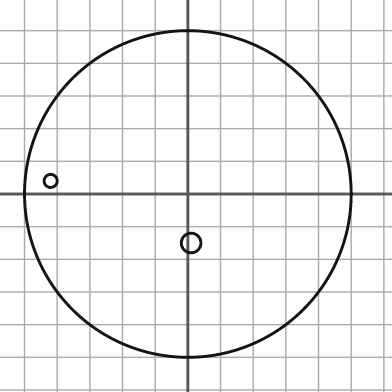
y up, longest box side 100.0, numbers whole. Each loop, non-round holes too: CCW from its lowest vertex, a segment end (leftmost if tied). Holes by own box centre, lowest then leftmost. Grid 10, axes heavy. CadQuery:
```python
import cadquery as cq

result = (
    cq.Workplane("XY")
    .moveTo(0.0, 0.0)
    .circle(50.0)
    .moveTo(1.0, -15.0)
    .circle(3.0)
    .moveTo(-42.0, 4.0)
    .circle(2.0)
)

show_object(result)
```